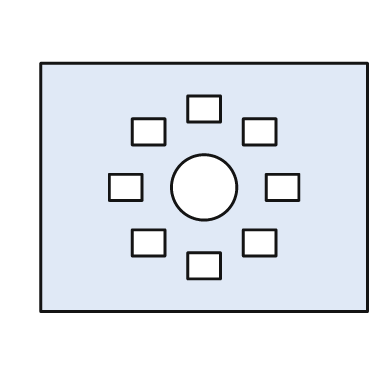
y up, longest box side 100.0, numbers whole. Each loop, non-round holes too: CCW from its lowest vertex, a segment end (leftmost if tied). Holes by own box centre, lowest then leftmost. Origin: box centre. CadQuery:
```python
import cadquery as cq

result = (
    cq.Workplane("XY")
    .moveTo(-50.0, -38.0)
    .lineTo(50.0, -38.0)
    .lineTo(50.0, 38.0)
    .lineTo(-50.0, 38.0)
    .close()
    .moveTo(-5.0, -28.0)
    .lineTo(5.0, -28.0)
    .lineTo(5.0, -20.0)
    .lineTo(-5.0, -20.0)
    .close()
    .moveTo(-22.0, -21.0)
    .lineTo(-12.0, -21.0)
    .lineTo(-12.0, -13.0)
    .lineTo(-22.0, -13.0)
    .close()
    .moveTo(12.0, -21.0)
    .lineTo(22.0, -21.0)
    .lineTo(22.0, -13.0)
    .lineTo(12.0, -13.0)
    .close()
    .moveTo(-29.0, -4.0)
    .lineTo(-19.0, -4.0)
    .lineTo(-19.0, 4.0)
    .lineTo(-29.0, 4.0)
    .close()
    .moveTo(0.0, 0.0)
    .circle(10.0)
    .moveTo(19.0, -4.0)
    .lineTo(29.0, -4.0)
    .lineTo(29.0, 4.0)
    .lineTo(19.0, 4.0)
    .close()
    .moveTo(-22.0, 13.0)
    .lineTo(-12.0, 13.0)
    .lineTo(-12.0, 21.0)
    .lineTo(-22.0, 21.0)
    .close()
    .moveTo(12.0, 13.0)
    .lineTo(22.0, 13.0)
    .lineTo(22.0, 21.0)
    .lineTo(12.0, 21.0)
    .close()
    .moveTo(-5.0, 20.0)
    .lineTo(5.0, 20.0)
    .lineTo(5.0, 28.0)
    .lineTo(-5.0, 28.0)
    .close()
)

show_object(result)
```